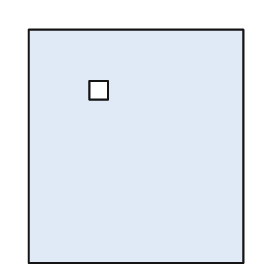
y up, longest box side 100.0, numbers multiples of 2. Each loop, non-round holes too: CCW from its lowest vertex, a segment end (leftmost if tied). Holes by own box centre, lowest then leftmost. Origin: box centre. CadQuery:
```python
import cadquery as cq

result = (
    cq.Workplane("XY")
    .moveTo(-46.0, -50.0)
    .lineTo(46.0, -50.0)
    .lineTo(46.0, 50.0)
    .lineTo(-46.0, 50.0)
    .close()
    .moveTo(-20.0, 20.0)
    .lineTo(-12.0, 20.0)
    .lineTo(-12.0, 28.0)
    .lineTo(-20.0, 28.0)
    .close()
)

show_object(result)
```